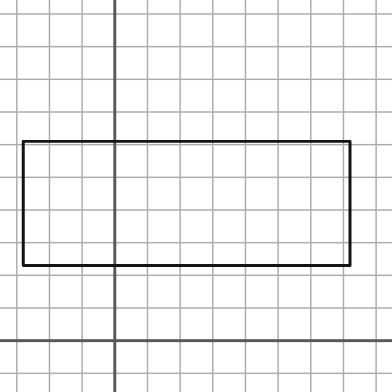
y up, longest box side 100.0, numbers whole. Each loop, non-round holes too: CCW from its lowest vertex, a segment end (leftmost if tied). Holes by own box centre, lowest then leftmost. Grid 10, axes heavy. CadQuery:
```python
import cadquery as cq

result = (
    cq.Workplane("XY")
    .moveTo(-28.0, 23.0)
    .lineTo(72.0, 23.0)
    .lineTo(72.0, 61.0)
    .lineTo(-28.0, 61.0)
    .close()
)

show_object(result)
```